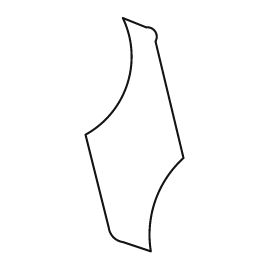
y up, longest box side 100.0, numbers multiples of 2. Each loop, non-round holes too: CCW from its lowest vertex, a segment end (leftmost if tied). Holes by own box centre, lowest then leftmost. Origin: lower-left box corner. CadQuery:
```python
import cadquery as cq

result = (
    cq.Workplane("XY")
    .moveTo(28.0, 0.0)
    .threePointArc((30.0, 22.0), (42.0, 40.0))
    .lineTo(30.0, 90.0)
    .threePointArc((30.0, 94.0), (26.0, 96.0))
    .lineTo(16.0, 100.0)
    .threePointArc((18.0, 72.0), (0.0, 50.0))
    .lineTo(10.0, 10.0)
    .threePointArc((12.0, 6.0), (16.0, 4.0))
    .close()
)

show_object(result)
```